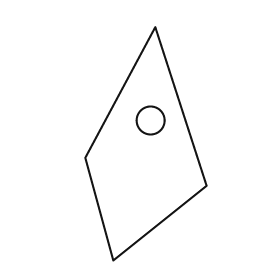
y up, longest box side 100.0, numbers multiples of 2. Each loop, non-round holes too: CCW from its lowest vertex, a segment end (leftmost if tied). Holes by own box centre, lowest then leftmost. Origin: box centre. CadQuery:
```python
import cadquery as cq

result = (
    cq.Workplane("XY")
    .moveTo(-14.0, -50.0)
    .lineTo(26.0, -18.0)
    .lineTo(4.0, 50.0)
    .lineTo(-26.0, -6.0)
    .close()
    .moveTo(2.0, 10.0)
    .circle(6.0)
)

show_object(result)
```